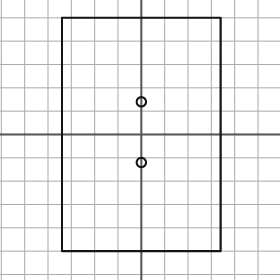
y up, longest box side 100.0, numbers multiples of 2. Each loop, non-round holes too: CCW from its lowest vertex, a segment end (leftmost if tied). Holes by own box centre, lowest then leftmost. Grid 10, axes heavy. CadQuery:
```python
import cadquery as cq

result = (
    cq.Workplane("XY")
    .moveTo(-34.0, -50.0)
    .lineTo(34.0, -50.0)
    .lineTo(34.0, 50.0)
    .lineTo(-34.0, 50.0)
    .close()
    .moveTo(0.0, -12.0)
    .circle(2.0)
    .moveTo(0.0, 14.0)
    .circle(2.0)
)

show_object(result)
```